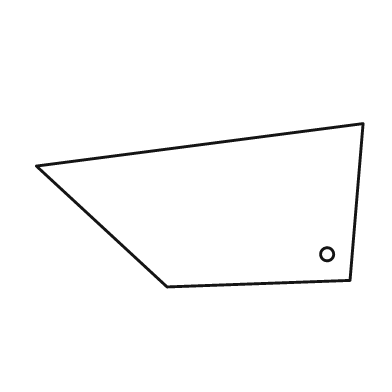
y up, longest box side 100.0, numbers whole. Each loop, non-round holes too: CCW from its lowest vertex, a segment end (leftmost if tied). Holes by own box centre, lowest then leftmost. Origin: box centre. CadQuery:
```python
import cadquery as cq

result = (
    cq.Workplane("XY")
    .moveTo(-10.0, -25.0)
    .lineTo(46.0, -23.0)
    .lineTo(50.0, 25.0)
    .lineTo(-50.0, 12.0)
    .close()
    .moveTo(39.0, -15.0)
    .circle(2.0)
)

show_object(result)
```